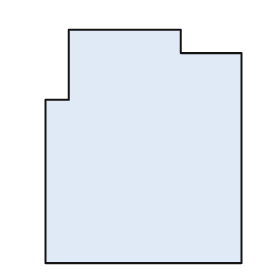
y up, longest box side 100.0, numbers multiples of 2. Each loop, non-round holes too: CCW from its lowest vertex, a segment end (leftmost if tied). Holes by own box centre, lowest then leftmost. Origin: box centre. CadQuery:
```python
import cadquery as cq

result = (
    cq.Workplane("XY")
    .moveTo(-42.0, -50.0)
    .lineTo(42.0, -50.0)
    .lineTo(42.0, 40.0)
    .lineTo(16.0, 40.0)
    .lineTo(16.0, 50.0)
    .lineTo(-32.0, 50.0)
    .lineTo(-32.0, 20.0)
    .lineTo(-42.0, 20.0)
    .close()
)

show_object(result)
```